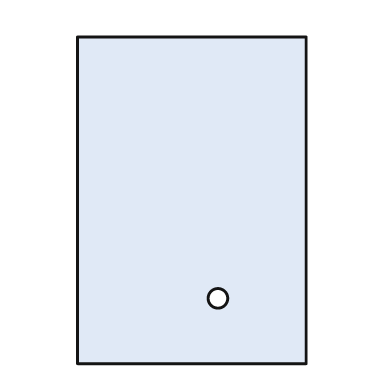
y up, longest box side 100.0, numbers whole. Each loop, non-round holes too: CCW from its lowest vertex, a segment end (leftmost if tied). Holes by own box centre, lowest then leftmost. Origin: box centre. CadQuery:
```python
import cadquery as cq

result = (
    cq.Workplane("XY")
    .moveTo(-35.0, -50.0)
    .lineTo(35.0, -50.0)
    .lineTo(35.0, 50.0)
    .lineTo(-35.0, 50.0)
    .close()
    .moveTo(8.0, -30.0)
    .circle(3.0)
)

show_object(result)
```